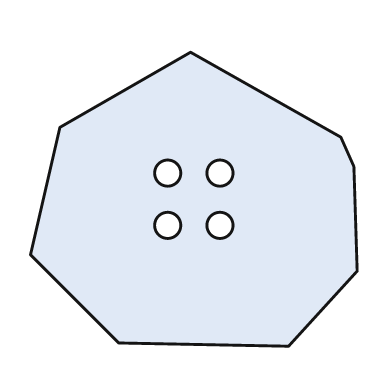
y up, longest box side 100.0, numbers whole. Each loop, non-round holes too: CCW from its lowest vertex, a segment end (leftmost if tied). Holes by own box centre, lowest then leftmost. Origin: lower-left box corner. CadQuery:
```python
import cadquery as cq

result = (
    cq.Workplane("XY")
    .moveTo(79.0, 0.0)
    .lineTo(100.0, 23.0)
    .lineTo(99.0, 55.0)
    .lineTo(95.0, 64.0)
    .lineTo(49.0, 90.0)
    .lineTo(9.0, 67.0)
    .lineTo(0.0, 28.0)
    .lineTo(27.0, 1.0)
    .close()
    .moveTo(42.0, 37.0)
    .circle(4.0)
    .moveTo(58.0, 37.0)
    .circle(4.0)
    .moveTo(42.0, 53.0)
    .circle(4.0)
    .moveTo(58.0, 53.0)
    .circle(4.0)
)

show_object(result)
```